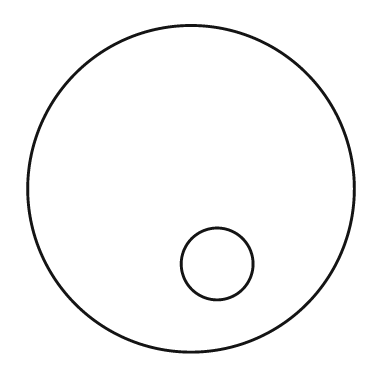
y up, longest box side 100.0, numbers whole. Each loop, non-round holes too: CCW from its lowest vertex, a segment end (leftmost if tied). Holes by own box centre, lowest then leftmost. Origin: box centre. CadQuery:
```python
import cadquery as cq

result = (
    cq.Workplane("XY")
    .moveTo(0.0, 0.0)
    .circle(50.0)
    .moveTo(8.0, -23.0)
    .circle(11.0)
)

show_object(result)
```